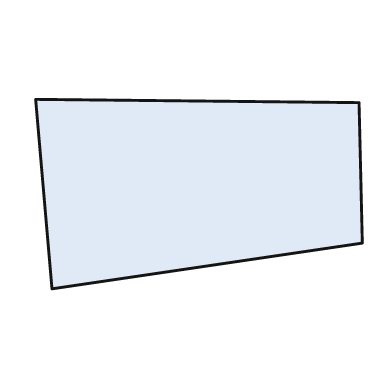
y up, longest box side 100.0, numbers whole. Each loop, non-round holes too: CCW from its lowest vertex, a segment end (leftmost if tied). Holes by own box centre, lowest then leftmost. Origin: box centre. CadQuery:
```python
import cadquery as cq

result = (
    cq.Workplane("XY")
    .moveTo(-45.0, -29.0)
    .lineTo(50.0, -15.0)
    .lineTo(49.0, 28.0)
    .lineTo(-50.0, 29.0)
    .close()
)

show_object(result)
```